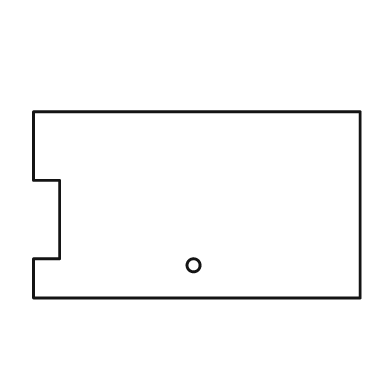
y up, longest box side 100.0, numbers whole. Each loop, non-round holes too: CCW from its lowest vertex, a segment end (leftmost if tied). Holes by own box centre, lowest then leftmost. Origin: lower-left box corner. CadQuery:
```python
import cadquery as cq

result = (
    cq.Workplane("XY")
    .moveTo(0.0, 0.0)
    .lineTo(100.0, 0.0)
    .lineTo(100.0, 57.0)
    .lineTo(0.0, 57.0)
    .lineTo(0.0, 36.0)
    .lineTo(8.0, 36.0)
    .lineTo(8.0, 12.0)
    .lineTo(0.0, 12.0)
    .close()
    .moveTo(49.0, 10.0)
    .circle(2.0)
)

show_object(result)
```